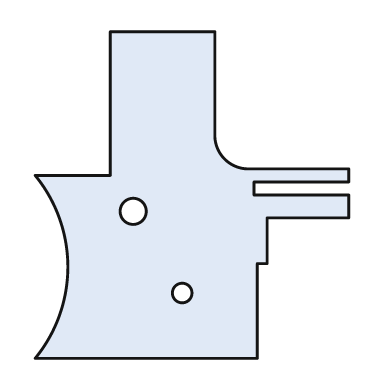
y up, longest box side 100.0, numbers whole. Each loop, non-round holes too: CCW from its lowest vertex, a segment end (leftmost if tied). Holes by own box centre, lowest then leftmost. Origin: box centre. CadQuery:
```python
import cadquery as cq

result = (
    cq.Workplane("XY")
    .moveTo(-48.0, -50.0)
    .lineTo(20.0, -50.0)
    .lineTo(20.0, -21.0)
    .lineTo(23.0, -21.0)
    .lineTo(23.0, -7.0)
    .lineTo(48.0, -7.0)
    .lineTo(48.0, 0.0)
    .lineTo(19.0, 0.0)
    .lineTo(19.0, 4.0)
    .lineTo(48.0, 4.0)
    .lineTo(48.0, 8.0)
    .lineTo(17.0, 8.0)
    .threePointArc((10.0, 11.0), (7.0, 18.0))
    .lineTo(7.0, 50.0)
    .lineTo(-25.0, 50.0)
    .lineTo(-25.0, 6.0)
    .lineTo(-48.0, 6.0)
    .threePointArc((-38.0, -22.0), (-48.0, -50.0))
    .close()
    .moveTo(-3.0, -30.0)
    .circle(3.0)
    .moveTo(-18.0, -5.0)
    .circle(4.0)
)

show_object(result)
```